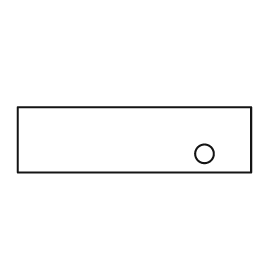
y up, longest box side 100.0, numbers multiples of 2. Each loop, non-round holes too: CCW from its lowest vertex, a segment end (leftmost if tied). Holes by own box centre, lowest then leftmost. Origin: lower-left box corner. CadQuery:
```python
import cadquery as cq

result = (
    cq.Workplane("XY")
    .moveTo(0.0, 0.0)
    .lineTo(100.0, 0.0)
    .lineTo(100.0, 28.0)
    .lineTo(0.0, 28.0)
    .close()
    .moveTo(80.0, 8.0)
    .circle(4.0)
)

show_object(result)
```